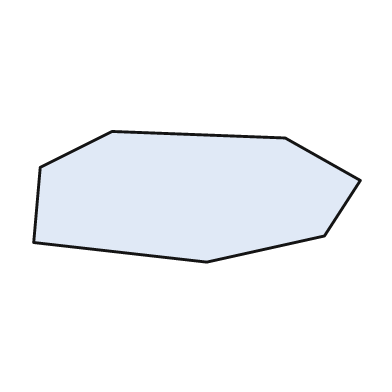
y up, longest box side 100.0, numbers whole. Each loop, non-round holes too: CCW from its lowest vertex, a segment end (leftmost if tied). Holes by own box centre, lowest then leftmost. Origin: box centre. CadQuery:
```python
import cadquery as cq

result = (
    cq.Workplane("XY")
    .moveTo(3.0, -20.0)
    .lineTo(39.0, -12.0)
    .lineTo(50.0, 5.0)
    .lineTo(27.0, 18.0)
    .lineTo(-26.0, 20.0)
    .lineTo(-48.0, 9.0)
    .lineTo(-50.0, -14.0)
    .close()
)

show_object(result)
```